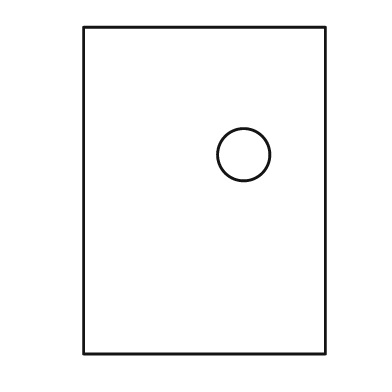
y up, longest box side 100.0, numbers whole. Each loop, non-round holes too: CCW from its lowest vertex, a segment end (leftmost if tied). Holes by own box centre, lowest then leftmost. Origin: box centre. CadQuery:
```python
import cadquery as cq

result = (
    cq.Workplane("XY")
    .moveTo(-37.0, -50.0)
    .lineTo(37.0, -50.0)
    .lineTo(37.0, 50.0)
    .lineTo(-37.0, 50.0)
    .close()
    .moveTo(12.0, 11.0)
    .circle(8.0)
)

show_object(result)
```